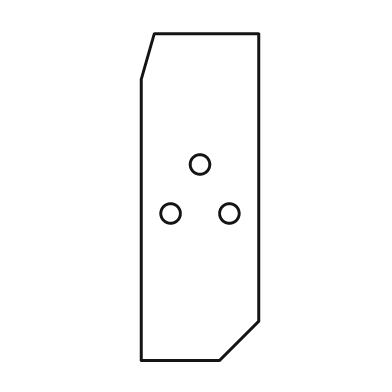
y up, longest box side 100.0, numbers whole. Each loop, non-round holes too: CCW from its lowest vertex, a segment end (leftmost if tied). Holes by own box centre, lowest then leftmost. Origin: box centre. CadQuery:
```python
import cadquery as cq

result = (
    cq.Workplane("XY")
    .moveTo(-18.0, -50.0)
    .lineTo(6.0, -50.0)
    .lineTo(18.0, -38.0)
    .lineTo(18.0, 50.0)
    .lineTo(-14.0, 50.0)
    .lineTo(-18.0, 36.0)
    .close()
    .moveTo(-9.0, -5.0)
    .circle(3.0)
    .moveTo(9.0, -5.0)
    .circle(3.0)
    .moveTo(0.0, 10.0)
    .circle(3.0)
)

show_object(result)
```